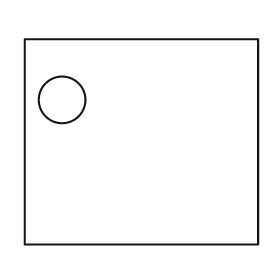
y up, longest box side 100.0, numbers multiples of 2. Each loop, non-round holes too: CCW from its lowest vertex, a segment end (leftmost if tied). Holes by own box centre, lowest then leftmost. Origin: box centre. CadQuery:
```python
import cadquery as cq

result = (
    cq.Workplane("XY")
    .moveTo(-50.0, -44.0)
    .lineTo(50.0, -44.0)
    .lineTo(50.0, 44.0)
    .lineTo(-50.0, 44.0)
    .close()
    .moveTo(-34.0, 18.0)
    .circle(10.0)
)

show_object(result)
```